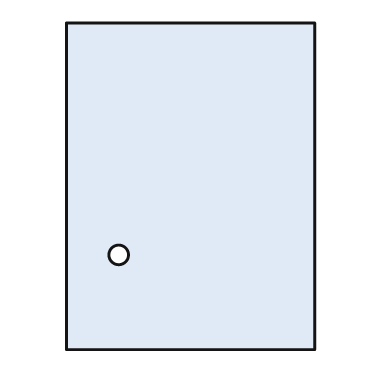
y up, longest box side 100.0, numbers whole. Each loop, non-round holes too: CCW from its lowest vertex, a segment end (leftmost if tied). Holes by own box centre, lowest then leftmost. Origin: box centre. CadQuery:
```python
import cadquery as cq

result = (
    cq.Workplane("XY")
    .moveTo(-38.0, -50.0)
    .lineTo(38.0, -50.0)
    .lineTo(38.0, 50.0)
    .lineTo(-38.0, 50.0)
    .close()
    .moveTo(-22.0, -21.0)
    .circle(3.0)
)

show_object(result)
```